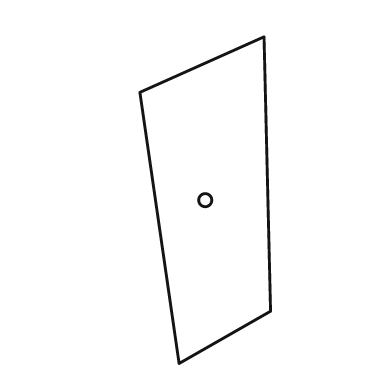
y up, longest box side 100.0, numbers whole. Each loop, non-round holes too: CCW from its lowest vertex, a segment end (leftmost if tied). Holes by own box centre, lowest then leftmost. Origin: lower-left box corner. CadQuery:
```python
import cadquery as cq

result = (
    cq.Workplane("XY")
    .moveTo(12.0, 0.0)
    .lineTo(40.0, 16.0)
    .lineTo(38.0, 100.0)
    .lineTo(0.0, 83.0)
    .close()
    .moveTo(20.0, 50.0)
    .circle(2.0)
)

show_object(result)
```